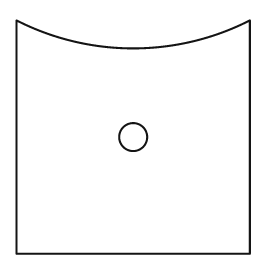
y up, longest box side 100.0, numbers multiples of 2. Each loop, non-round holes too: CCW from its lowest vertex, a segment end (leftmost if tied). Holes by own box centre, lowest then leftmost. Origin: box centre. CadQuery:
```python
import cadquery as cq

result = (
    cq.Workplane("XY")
    .moveTo(-50.0, -50.0)
    .lineTo(50.0, -50.0)
    .lineTo(50.0, 50.0)
    .threePointArc((0.0, 38.0), (-50.0, 50.0))
    .close()
    .moveTo(0.0, 0.0)
    .circle(6.0)
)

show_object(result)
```